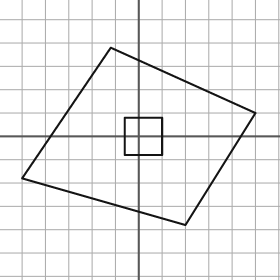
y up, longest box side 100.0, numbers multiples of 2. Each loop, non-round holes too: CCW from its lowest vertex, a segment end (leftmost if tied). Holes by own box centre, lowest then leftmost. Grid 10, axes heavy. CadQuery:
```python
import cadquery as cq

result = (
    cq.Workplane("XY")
    .moveTo(20.0, -38.0)
    .lineTo(50.0, 10.0)
    .lineTo(-12.0, 38.0)
    .lineTo(-50.0, -18.0)
    .close()
    .moveTo(-6.0, -8.0)
    .lineTo(10.0, -8.0)
    .lineTo(10.0, 8.0)
    .lineTo(-6.0, 8.0)
    .close()
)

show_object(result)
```